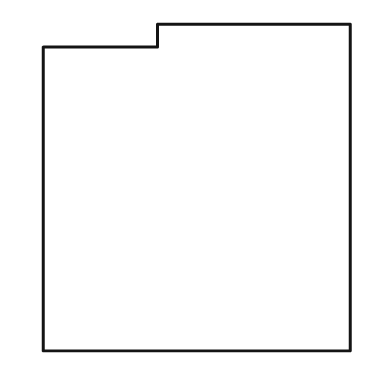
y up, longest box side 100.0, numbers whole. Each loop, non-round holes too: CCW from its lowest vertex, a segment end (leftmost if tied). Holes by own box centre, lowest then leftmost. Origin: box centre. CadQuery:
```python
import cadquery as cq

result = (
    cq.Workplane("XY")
    .moveTo(-47.0, -50.0)
    .lineTo(47.0, -50.0)
    .lineTo(47.0, 50.0)
    .lineTo(-12.0, 50.0)
    .lineTo(-12.0, 43.0)
    .lineTo(-47.0, 43.0)
    .close()
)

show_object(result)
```